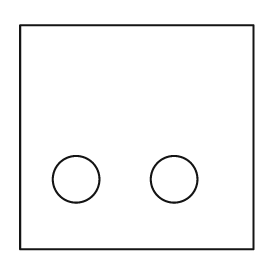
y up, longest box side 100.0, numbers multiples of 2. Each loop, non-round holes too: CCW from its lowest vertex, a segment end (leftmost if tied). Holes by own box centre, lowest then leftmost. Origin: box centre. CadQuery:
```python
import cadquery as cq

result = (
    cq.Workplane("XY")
    .moveTo(-50.0, -48.0)
    .lineTo(50.0, -48.0)
    .lineTo(50.0, 48.0)
    .lineTo(-50.0, 48.0)
    .close()
    .moveTo(-26.0, -18.0)
    .circle(10.0)
    .moveTo(16.0, -18.0)
    .circle(10.0)
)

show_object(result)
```